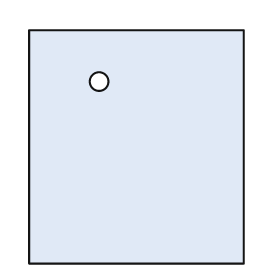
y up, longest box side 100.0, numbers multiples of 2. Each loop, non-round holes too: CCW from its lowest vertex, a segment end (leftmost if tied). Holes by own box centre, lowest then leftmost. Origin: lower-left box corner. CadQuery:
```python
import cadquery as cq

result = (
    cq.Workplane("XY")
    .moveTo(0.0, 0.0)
    .lineTo(92.0, 0.0)
    .lineTo(92.0, 100.0)
    .lineTo(0.0, 100.0)
    .close()
    .moveTo(30.0, 78.0)
    .circle(4.0)
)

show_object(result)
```